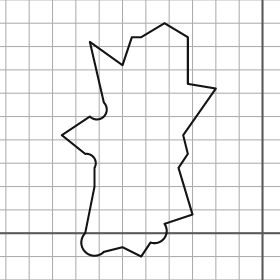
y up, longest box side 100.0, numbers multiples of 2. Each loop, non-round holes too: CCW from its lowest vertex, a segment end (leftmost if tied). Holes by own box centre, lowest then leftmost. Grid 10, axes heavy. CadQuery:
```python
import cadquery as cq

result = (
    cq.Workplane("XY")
    .moveTo(-52.0, -10.0)
    .lineTo(-48.0, -4.0)
    .threePointArc((-42.0, -2.0), (-42.0, 4.0))
    .lineTo(-30.0, 8.0)
    .lineTo(-36.0, 28.0)
    .lineTo(-32.0, 34.0)
    .lineTo(-34.0, 42.0)
    .lineTo(-20.0, 62.0)
    .lineTo(-32.0, 64.0)
    .lineTo(-32.0, 84.0)
    .lineTo(-42.0, 90.0)
    .lineTo(-52.0, 84.0)
    .lineTo(-56.0, 84.0)
    .lineTo(-60.0, 72.0)
    .lineTo(-74.0, 82.0)
    .lineTo(-68.0, 56.0)
    .threePointArc((-68.0, 50.0), (-74.0, 50.0))
    .lineTo(-86.0, 42.0)
    .lineTo(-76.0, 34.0)
    .threePointArc((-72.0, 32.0), (-72.0, 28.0))
    .lineTo(-72.0, 20.0)
    .lineTo(-76.0, 0.0)
    .threePointArc((-76.0, -8.0), (-68.0, -8.0))
    .lineTo(-60.0, -6.0)
    .close()
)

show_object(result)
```